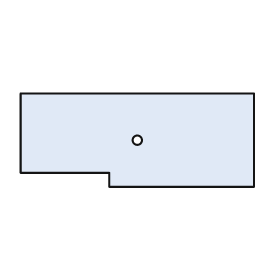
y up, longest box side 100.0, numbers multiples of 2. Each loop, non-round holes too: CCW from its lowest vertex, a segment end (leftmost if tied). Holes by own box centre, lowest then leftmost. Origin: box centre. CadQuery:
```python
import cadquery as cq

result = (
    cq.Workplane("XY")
    .moveTo(-12.0, -20.0)
    .lineTo(50.0, -20.0)
    .lineTo(50.0, 20.0)
    .lineTo(-50.0, 20.0)
    .lineTo(-50.0, -14.0)
    .lineTo(-12.0, -14.0)
    .close()
    .moveTo(0.0, 0.0)
    .circle(2.0)
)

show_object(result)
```